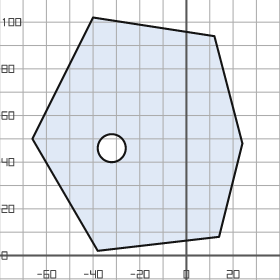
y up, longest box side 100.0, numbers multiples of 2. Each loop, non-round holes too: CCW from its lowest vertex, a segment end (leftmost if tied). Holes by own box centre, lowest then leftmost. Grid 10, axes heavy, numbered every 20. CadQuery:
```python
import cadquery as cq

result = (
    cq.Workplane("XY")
    .moveTo(-38.0, 2.0)
    .lineTo(14.0, 8.0)
    .lineTo(24.0, 48.0)
    .lineTo(12.0, 94.0)
    .lineTo(-40.0, 102.0)
    .lineTo(-66.0, 50.0)
    .close()
    .moveTo(-32.0, 46.0)
    .circle(6.0)
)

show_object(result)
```